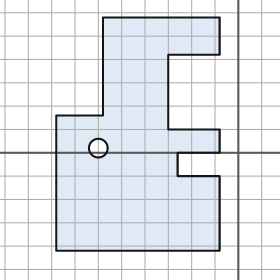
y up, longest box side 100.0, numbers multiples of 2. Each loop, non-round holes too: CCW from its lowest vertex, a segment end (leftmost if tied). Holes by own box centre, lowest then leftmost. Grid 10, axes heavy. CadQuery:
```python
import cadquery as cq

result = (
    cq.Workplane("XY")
    .moveTo(-78.0, -42.0)
    .lineTo(-8.0, -42.0)
    .lineTo(-8.0, -10.0)
    .lineTo(-26.0, -10.0)
    .lineTo(-26.0, 0.0)
    .lineTo(-8.0, 0.0)
    .lineTo(-8.0, 10.0)
    .lineTo(-30.0, 10.0)
    .lineTo(-30.0, 42.0)
    .lineTo(-8.0, 42.0)
    .lineTo(-8.0, 58.0)
    .lineTo(-58.0, 58.0)
    .lineTo(-58.0, 16.0)
    .lineTo(-78.0, 16.0)
    .close()
    .moveTo(-60.0, 2.0)
    .circle(4.0)
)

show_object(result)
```